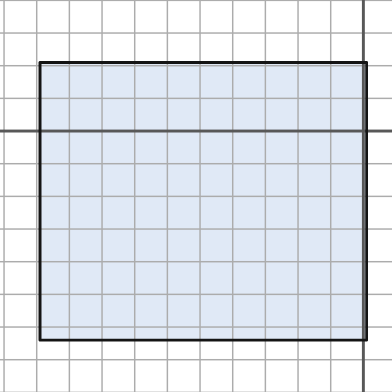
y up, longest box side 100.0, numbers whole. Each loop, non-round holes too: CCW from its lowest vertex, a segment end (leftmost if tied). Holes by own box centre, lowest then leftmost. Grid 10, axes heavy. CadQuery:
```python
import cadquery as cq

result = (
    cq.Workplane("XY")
    .moveTo(-99.0, -64.0)
    .lineTo(1.0, -64.0)
    .lineTo(1.0, 21.0)
    .lineTo(-99.0, 21.0)
    .close()
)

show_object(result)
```